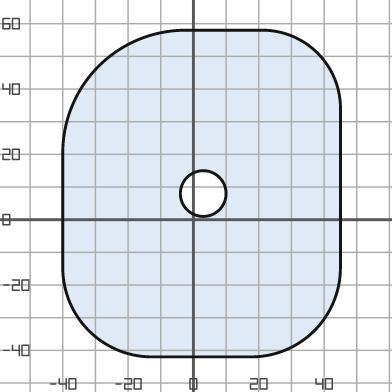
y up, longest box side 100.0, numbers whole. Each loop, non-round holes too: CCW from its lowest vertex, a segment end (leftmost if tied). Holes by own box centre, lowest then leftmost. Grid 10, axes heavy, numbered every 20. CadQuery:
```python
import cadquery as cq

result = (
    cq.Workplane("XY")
    .moveTo(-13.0, -42.0)
    .lineTo(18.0, -42.0)
    .threePointArc((37.0, -34.0), (45.0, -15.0))
    .lineTo(45.0, 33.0)
    .threePointArc((38.0, 51.0), (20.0, 58.0))
    .lineTo(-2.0, 58.0)
    .threePointArc((-29.0, 47.0), (-40.0, 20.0))
    .lineTo(-40.0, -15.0)
    .threePointArc((-32.0, -34.0), (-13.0, -42.0))
    .close()
    .moveTo(3.0, 8.0)
    .circle(7.0)
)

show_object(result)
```